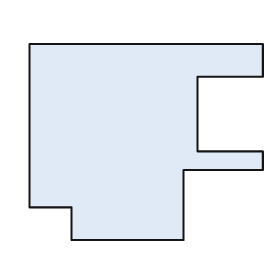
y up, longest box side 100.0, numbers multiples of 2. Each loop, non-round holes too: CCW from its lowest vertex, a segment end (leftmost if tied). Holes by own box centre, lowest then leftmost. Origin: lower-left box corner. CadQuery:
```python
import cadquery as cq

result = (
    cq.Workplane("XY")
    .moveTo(18.0, 0.0)
    .lineTo(66.0, 0.0)
    .lineTo(66.0, 30.0)
    .lineTo(100.0, 30.0)
    .lineTo(100.0, 38.0)
    .lineTo(72.0, 38.0)
    .lineTo(72.0, 70.0)
    .lineTo(100.0, 70.0)
    .lineTo(100.0, 84.0)
    .lineTo(0.0, 84.0)
    .lineTo(0.0, 14.0)
    .lineTo(18.0, 14.0)
    .close()
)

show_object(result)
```